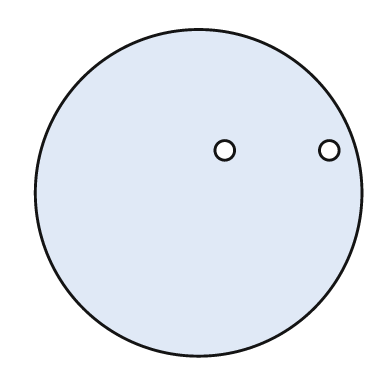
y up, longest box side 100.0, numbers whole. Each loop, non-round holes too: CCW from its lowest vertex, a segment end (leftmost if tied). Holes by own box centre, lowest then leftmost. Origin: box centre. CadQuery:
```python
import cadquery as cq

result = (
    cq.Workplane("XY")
    .moveTo(0.0, 0.0)
    .circle(50.0)
    .moveTo(8.0, 13.0)
    .circle(3.0)
    .moveTo(40.0, 13.0)
    .circle(3.0)
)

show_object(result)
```